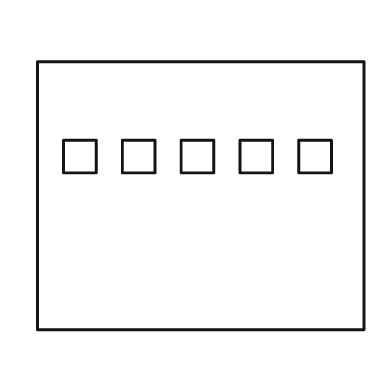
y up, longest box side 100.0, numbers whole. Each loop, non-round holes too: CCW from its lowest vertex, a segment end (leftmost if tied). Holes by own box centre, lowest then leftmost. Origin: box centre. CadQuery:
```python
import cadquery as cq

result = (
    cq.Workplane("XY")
    .moveTo(-50.0, -41.0)
    .lineTo(50.0, -41.0)
    .lineTo(50.0, 41.0)
    .lineTo(-50.0, 41.0)
    .close()
    .moveTo(-42.0, 7.0)
    .lineTo(-32.0, 7.0)
    .lineTo(-32.0, 17.0)
    .lineTo(-42.0, 17.0)
    .close()
    .moveTo(-24.0, 7.0)
    .lineTo(-14.0, 7.0)
    .lineTo(-14.0, 17.0)
    .lineTo(-24.0, 17.0)
    .close()
    .moveTo(-6.0, 7.0)
    .lineTo(4.0, 7.0)
    .lineTo(4.0, 17.0)
    .lineTo(-6.0, 17.0)
    .close()
    .moveTo(12.0, 7.0)
    .lineTo(22.0, 7.0)
    .lineTo(22.0, 17.0)
    .lineTo(12.0, 17.0)
    .close()
    .moveTo(30.0, 7.0)
    .lineTo(40.0, 7.0)
    .lineTo(40.0, 17.0)
    .lineTo(30.0, 17.0)
    .close()
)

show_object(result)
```